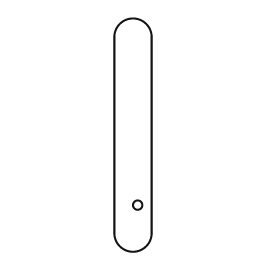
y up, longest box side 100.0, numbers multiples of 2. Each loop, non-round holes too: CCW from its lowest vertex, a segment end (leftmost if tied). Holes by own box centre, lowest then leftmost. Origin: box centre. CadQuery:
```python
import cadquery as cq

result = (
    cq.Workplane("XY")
    .moveTo(-8.0, -42.0)
    .threePointArc((0.0, -50.0), (8.0, -42.0))
    .lineTo(8.0, 42.0)
    .threePointArc((0.0, 50.0), (-8.0, 42.0))
    .close()
    .moveTo(2.0, -30.0)
    .circle(2.0)
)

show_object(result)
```